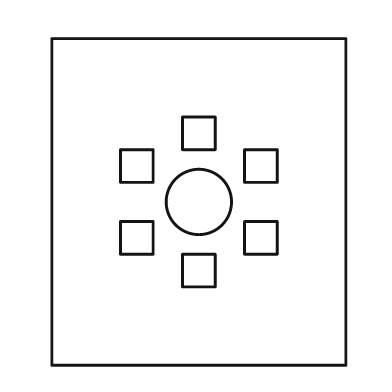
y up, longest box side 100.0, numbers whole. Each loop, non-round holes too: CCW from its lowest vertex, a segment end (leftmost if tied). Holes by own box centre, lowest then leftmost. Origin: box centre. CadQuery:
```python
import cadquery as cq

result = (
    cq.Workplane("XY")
    .moveTo(-45.0, -50.0)
    .lineTo(45.0, -50.0)
    .lineTo(45.0, 50.0)
    .lineTo(-45.0, 50.0)
    .close()
    .moveTo(-5.0, -26.0)
    .lineTo(5.0, -26.0)
    .lineTo(5.0, -16.0)
    .lineTo(-5.0, -16.0)
    .close()
    .moveTo(-24.0, -16.0)
    .lineTo(-14.0, -16.0)
    .lineTo(-14.0, -6.0)
    .lineTo(-24.0, -6.0)
    .close()
    .moveTo(14.0, -16.0)
    .lineTo(24.0, -16.0)
    .lineTo(24.0, -6.0)
    .lineTo(14.0, -6.0)
    .close()
    .moveTo(0.0, 0.0)
    .circle(10.0)
    .moveTo(-24.0, 6.0)
    .lineTo(-14.0, 6.0)
    .lineTo(-14.0, 16.0)
    .lineTo(-24.0, 16.0)
    .close()
    .moveTo(14.0, 6.0)
    .lineTo(24.0, 6.0)
    .lineTo(24.0, 16.0)
    .lineTo(14.0, 16.0)
    .close()
    .moveTo(-5.0, 16.0)
    .lineTo(5.0, 16.0)
    .lineTo(5.0, 26.0)
    .lineTo(-5.0, 26.0)
    .close()
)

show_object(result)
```